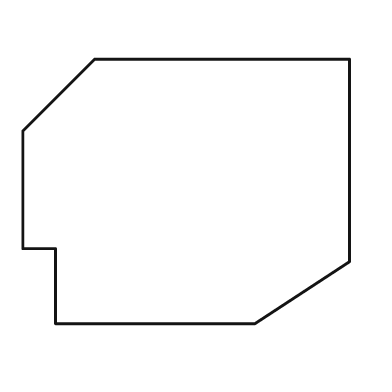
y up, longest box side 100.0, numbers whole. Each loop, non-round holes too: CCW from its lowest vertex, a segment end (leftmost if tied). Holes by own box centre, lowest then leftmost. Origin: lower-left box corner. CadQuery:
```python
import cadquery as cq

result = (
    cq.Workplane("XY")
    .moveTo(10.0, 0.0)
    .lineTo(71.0, 0.0)
    .lineTo(100.0, 19.0)
    .lineTo(100.0, 81.0)
    .lineTo(22.0, 81.0)
    .lineTo(0.0, 59.0)
    .lineTo(0.0, 23.0)
    .lineTo(10.0, 23.0)
    .close()
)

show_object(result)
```